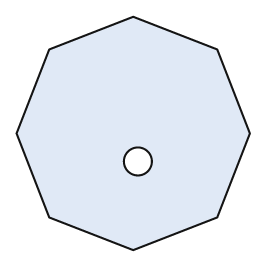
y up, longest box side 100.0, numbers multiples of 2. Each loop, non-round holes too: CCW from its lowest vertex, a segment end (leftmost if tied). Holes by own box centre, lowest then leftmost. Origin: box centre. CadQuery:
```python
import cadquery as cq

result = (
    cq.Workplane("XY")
    .moveTo(0.0, -50.0)
    .lineTo(36.0, -36.0)
    .lineTo(50.0, 0.0)
    .lineTo(36.0, 36.0)
    .lineTo(0.0, 50.0)
    .lineTo(-36.0, 36.0)
    .lineTo(-50.0, 0.0)
    .lineTo(-36.0, -36.0)
    .close()
    .moveTo(2.0, -12.0)
    .circle(6.0)
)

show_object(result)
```